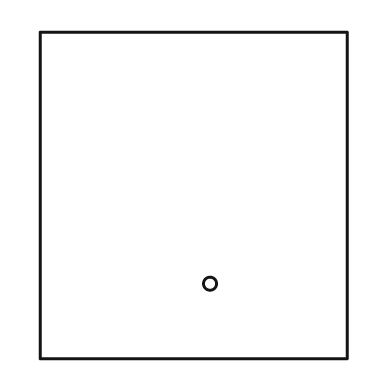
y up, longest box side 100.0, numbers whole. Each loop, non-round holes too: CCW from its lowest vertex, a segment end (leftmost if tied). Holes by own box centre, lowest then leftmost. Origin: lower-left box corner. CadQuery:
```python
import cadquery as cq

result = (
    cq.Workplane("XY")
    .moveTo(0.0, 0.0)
    .lineTo(94.0, 0.0)
    .lineTo(94.0, 100.0)
    .lineTo(0.0, 100.0)
    .close()
    .moveTo(52.0, 23.0)
    .circle(2.0)
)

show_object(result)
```